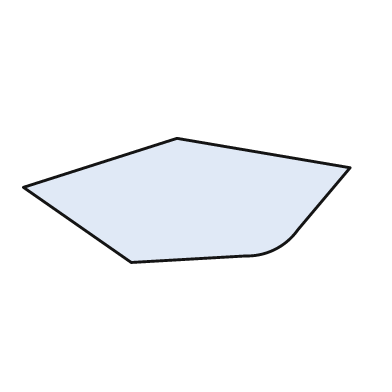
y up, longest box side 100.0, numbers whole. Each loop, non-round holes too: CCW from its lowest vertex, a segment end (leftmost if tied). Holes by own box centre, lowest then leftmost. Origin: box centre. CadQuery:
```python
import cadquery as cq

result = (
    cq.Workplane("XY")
    .moveTo(-17.0, -19.0)
    .lineTo(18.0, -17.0)
    .threePointArc((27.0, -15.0), (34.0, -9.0))
    .lineTo(50.0, 10.0)
    .lineTo(-3.0, 19.0)
    .lineTo(-50.0, 4.0)
    .close()
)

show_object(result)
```